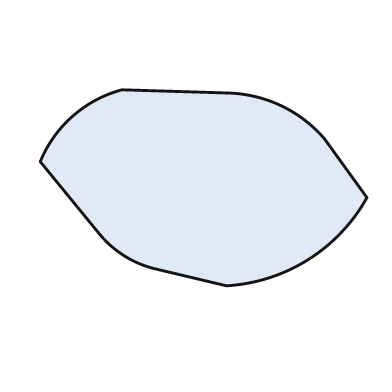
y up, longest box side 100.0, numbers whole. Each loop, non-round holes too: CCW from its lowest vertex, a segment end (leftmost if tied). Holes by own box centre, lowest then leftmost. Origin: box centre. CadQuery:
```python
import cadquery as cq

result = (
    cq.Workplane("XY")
    .moveTo(7.0, -30.0)
    .threePointArc((32.0, -22.0), (50.0, -3.0))
    .lineTo(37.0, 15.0)
    .threePointArc((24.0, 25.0), (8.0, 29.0))
    .lineTo(-25.0, 30.0)
    .threePointArc((-40.0, 22.0), (-50.0, 8.0))
    .lineTo(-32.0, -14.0)
    .threePointArc((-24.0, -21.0), (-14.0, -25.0))
    .close()
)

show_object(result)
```